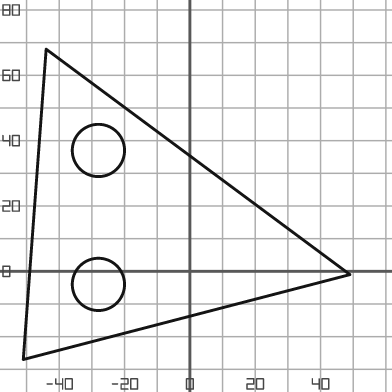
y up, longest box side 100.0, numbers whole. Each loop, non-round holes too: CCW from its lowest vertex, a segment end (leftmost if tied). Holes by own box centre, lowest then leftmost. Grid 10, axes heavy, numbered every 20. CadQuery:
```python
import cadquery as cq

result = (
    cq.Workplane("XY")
    .moveTo(-51.0, -27.0)
    .lineTo(49.0, -1.0)
    .lineTo(-44.0, 68.0)
    .close()
    .moveTo(-28.0, -4.0)
    .circle(8.0)
    .moveTo(-28.0, 37.0)
    .circle(8.0)
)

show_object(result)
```